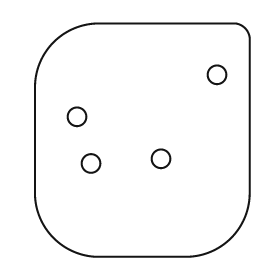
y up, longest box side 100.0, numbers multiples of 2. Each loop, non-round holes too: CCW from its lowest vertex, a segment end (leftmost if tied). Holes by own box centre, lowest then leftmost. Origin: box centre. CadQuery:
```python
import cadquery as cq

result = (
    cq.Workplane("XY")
    .moveTo(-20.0, -50.0)
    .lineTo(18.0, -50.0)
    .threePointArc((38.0, -42.0), (46.0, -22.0))
    .lineTo(46.0, 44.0)
    .threePointArc((44.0, 48.0), (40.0, 50.0))
    .lineTo(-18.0, 50.0)
    .threePointArc((-38.0, 42.0), (-46.0, 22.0))
    .lineTo(-46.0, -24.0)
    .threePointArc((-38.0, -42.0), (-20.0, -50.0))
    .close()
    .moveTo(-22.0, -10.0)
    .circle(4.0)
    .moveTo(8.0, -8.0)
    .circle(4.0)
    .moveTo(-28.0, 10.0)
    .circle(4.0)
    .moveTo(32.0, 28.0)
    .circle(4.0)
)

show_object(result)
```